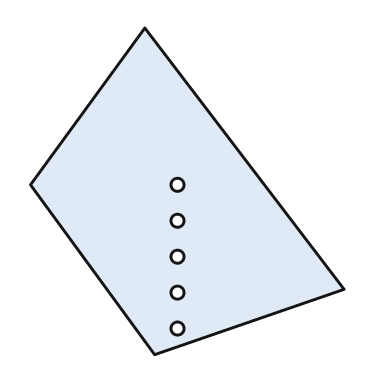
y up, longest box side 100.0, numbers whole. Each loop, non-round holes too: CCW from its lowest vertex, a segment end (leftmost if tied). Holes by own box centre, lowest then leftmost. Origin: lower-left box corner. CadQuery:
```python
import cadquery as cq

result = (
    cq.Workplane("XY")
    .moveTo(38.0, 0.0)
    .lineTo(96.0, 20.0)
    .lineTo(35.0, 100.0)
    .lineTo(0.0, 52.0)
    .close()
    .moveTo(45.0, 8.0)
    .circle(2.0)
    .moveTo(45.0, 19.0)
    .circle(2.0)
    .moveTo(45.0, 30.0)
    .circle(2.0)
    .moveTo(45.0, 41.0)
    .circle(2.0)
    .moveTo(45.0, 52.0)
    .circle(2.0)
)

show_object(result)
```